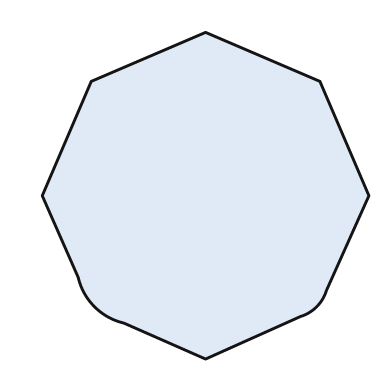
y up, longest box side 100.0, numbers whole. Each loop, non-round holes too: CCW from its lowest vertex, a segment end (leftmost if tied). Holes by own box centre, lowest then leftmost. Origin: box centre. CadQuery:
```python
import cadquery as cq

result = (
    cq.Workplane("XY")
    .moveTo(0.0, -50.0)
    .lineTo(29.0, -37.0)
    .threePointArc((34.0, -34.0), (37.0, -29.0))
    .lineTo(50.0, 0.0)
    .lineTo(35.0, 35.0)
    .lineTo(0.0, 50.0)
    .lineTo(-35.0, 35.0)
    .lineTo(-50.0, 0.0)
    .lineTo(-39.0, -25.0)
    .threePointArc((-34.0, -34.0), (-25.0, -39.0))
    .close()
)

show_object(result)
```